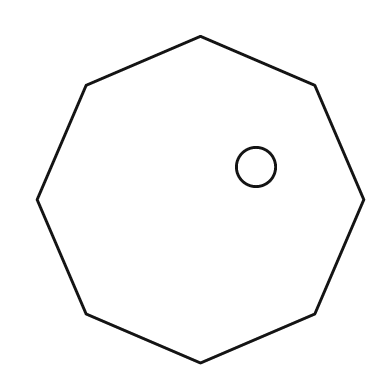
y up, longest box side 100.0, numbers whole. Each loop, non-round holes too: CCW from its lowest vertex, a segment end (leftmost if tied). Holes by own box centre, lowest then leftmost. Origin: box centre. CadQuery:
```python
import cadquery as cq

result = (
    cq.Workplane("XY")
    .moveTo(0.0, -50.0)
    .lineTo(35.0, -35.0)
    .lineTo(50.0, 0.0)
    .lineTo(35.0, 35.0)
    .lineTo(0.0, 50.0)
    .lineTo(-35.0, 35.0)
    .lineTo(-50.0, 0.0)
    .lineTo(-35.0, -35.0)
    .close()
    .moveTo(17.0, 10.0)
    .circle(6.0)
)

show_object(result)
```